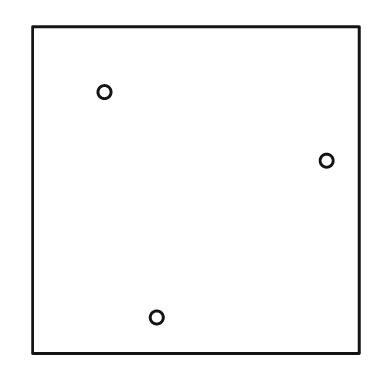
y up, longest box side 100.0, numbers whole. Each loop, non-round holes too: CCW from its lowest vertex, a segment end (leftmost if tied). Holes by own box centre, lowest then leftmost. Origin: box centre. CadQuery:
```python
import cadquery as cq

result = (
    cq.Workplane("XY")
    .moveTo(-50.0, -50.0)
    .lineTo(50.0, -50.0)
    .lineTo(50.0, 50.0)
    .lineTo(-50.0, 50.0)
    .close()
    .moveTo(-12.0, -39.0)
    .circle(2.0)
    .moveTo(40.0, 9.0)
    .circle(2.0)
    .moveTo(-28.0, 30.0)
    .circle(2.0)
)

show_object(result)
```